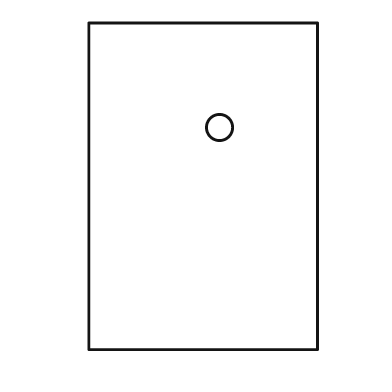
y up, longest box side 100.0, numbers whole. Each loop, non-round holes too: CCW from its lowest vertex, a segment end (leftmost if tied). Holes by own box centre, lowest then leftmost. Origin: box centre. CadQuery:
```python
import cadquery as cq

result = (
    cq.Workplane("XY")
    .moveTo(-35.0, -50.0)
    .lineTo(35.0, -50.0)
    .lineTo(35.0, 50.0)
    .lineTo(-35.0, 50.0)
    .close()
    .moveTo(5.0, 18.0)
    .circle(4.0)
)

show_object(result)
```